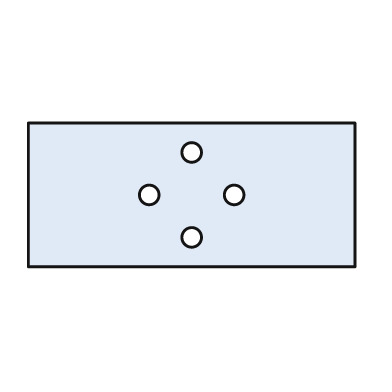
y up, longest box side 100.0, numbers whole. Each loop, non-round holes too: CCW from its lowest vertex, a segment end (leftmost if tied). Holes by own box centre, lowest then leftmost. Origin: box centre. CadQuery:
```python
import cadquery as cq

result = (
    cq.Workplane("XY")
    .moveTo(-50.0, -22.0)
    .lineTo(50.0, -22.0)
    .lineTo(50.0, 22.0)
    .lineTo(-50.0, 22.0)
    .close()
    .moveTo(0.0, -13.0)
    .circle(3.0)
    .moveTo(-13.0, 0.0)
    .circle(3.0)
    .moveTo(13.0, 0.0)
    .circle(3.0)
    .moveTo(0.0, 13.0)
    .circle(3.0)
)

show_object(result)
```